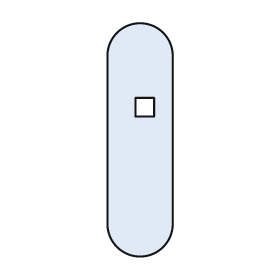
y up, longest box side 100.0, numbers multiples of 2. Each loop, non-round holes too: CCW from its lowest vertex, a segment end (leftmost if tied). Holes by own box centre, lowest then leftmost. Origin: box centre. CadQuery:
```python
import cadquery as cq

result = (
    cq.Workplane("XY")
    .moveTo(-14.0, -36.0)
    .threePointArc((0.0, -50.0), (14.0, -36.0))
    .lineTo(14.0, 36.0)
    .threePointArc((0.0, 50.0), (-14.0, 36.0))
    .close()
    .moveTo(-2.0, 10.0)
    .lineTo(6.0, 10.0)
    .lineTo(6.0, 18.0)
    .lineTo(-2.0, 18.0)
    .close()
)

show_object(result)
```